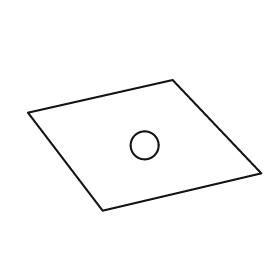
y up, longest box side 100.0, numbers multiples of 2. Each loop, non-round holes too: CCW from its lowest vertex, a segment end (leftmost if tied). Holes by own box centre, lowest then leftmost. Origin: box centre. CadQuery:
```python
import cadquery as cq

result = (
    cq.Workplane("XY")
    .moveTo(-18.0, -28.0)
    .lineTo(50.0, -12.0)
    .lineTo(12.0, 28.0)
    .lineTo(-50.0, 14.0)
    .close()
    .moveTo(0.0, 0.0)
    .circle(6.0)
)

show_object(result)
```